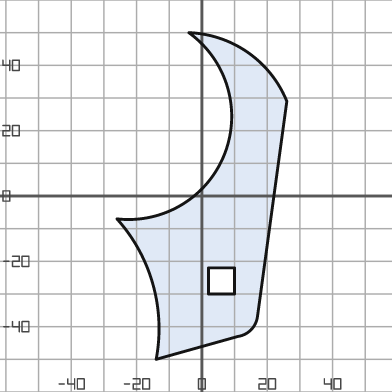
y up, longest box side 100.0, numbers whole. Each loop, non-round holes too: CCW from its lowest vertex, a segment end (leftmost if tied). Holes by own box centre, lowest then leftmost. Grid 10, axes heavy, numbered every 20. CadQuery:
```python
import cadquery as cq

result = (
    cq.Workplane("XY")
    .moveTo(-14.0, -50.0)
    .lineTo(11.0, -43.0)
    .threePointArc((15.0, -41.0), (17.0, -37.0))
    .lineTo(26.0, 29.0)
    .threePointArc((14.0, 44.0), (-4.0, 50.0))
    .threePointArc((7.0, 13.0), (-26.0, -7.0))
    .threePointArc((-15.0, -27.0), (-14.0, -50.0))
    .close()
    .moveTo(2.0, -30.0)
    .lineTo(10.0, -30.0)
    .lineTo(10.0, -22.0)
    .lineTo(2.0, -22.0)
    .close()
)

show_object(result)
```